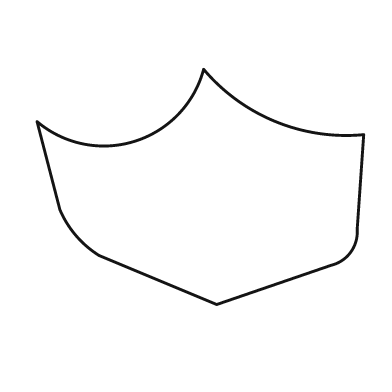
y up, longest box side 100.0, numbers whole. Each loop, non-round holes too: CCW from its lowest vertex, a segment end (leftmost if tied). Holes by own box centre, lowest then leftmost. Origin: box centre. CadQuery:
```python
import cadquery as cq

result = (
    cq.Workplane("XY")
    .moveTo(5.0, -36.0)
    .lineTo(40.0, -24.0)
    .threePointArc((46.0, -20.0), (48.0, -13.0))
    .lineTo(50.0, 16.0)
    .threePointArc((23.0, 20.0), (1.0, 36.0))
    .threePointArc((-20.0, 14.0), (-50.0, 20.0))
    .lineTo(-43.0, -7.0)
    .threePointArc((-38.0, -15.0), (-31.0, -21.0))
    .close()
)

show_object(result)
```